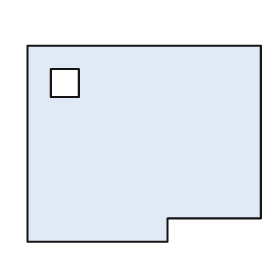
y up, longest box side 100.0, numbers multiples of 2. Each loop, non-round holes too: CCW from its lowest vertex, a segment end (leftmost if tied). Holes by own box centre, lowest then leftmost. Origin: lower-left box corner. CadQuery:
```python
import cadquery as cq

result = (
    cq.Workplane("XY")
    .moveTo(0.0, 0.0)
    .lineTo(60.0, 0.0)
    .lineTo(60.0, 10.0)
    .lineTo(100.0, 10.0)
    .lineTo(100.0, 84.0)
    .lineTo(0.0, 84.0)
    .close()
    .moveTo(10.0, 62.0)
    .lineTo(22.0, 62.0)
    .lineTo(22.0, 74.0)
    .lineTo(10.0, 74.0)
    .close()
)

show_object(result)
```